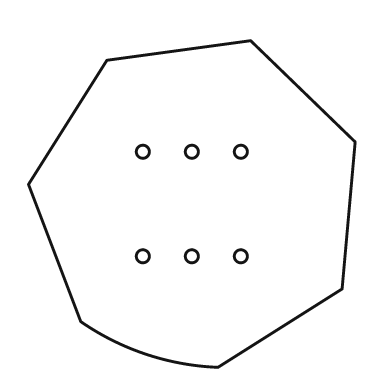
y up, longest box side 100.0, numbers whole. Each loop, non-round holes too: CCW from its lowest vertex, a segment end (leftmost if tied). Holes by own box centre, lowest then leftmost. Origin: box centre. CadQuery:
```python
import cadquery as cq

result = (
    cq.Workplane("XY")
    .moveTo(8.0, -50.0)
    .lineTo(46.0, -26.0)
    .lineTo(50.0, 19.0)
    .lineTo(18.0, 50.0)
    .lineTo(-26.0, 44.0)
    .lineTo(-50.0, 6.0)
    .lineTo(-34.0, -36.0)
    .threePointArc((-14.0, -46.0), (8.0, -50.0))
    .close()
    .moveTo(-15.0, -16.0)
    .circle(2.0)
    .moveTo(0.0, -16.0)
    .circle(2.0)
    .moveTo(15.0, -16.0)
    .circle(2.0)
    .moveTo(-15.0, 16.0)
    .circle(2.0)
    .moveTo(0.0, 16.0)
    .circle(2.0)
    .moveTo(15.0, 16.0)
    .circle(2.0)
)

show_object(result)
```